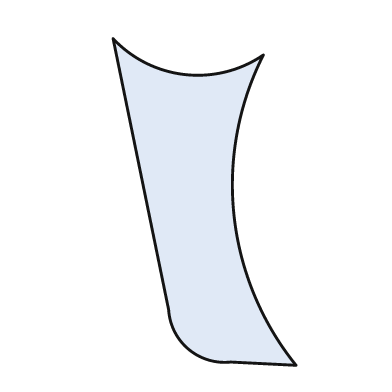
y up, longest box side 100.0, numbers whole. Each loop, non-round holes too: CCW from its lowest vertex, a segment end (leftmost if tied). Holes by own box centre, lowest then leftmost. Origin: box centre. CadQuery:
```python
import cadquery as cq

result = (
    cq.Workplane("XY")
    .moveTo(28.0, -50.0)
    .threePointArc((9.0, -4.0), (18.0, 45.0))
    .threePointArc((-6.0, 39.0), (-28.0, 50.0))
    .lineTo(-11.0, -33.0)
    .threePointArc((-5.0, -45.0), (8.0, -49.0))
    .close()
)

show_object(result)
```